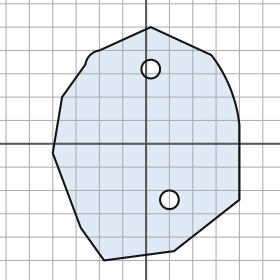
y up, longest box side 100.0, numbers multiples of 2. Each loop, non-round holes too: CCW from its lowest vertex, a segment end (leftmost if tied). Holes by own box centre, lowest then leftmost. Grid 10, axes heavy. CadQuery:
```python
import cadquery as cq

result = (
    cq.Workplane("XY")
    .moveTo(-18.0, -50.0)
    .lineTo(12.0, -46.0)
    .lineTo(40.0, -24.0)
    .lineTo(40.0, 8.0)
    .threePointArc((36.0, 24.0), (28.0, 38.0))
    .lineTo(2.0, 50.0)
    .lineTo(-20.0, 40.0)
    .threePointArc((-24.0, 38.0), (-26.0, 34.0))
    .lineTo(-36.0, 20.0)
    .lineTo(-40.0, -4.0)
    .lineTo(-28.0, -36.0)
    .close()
    .moveTo(10.0, -24.0)
    .circle(4.0)
    .moveTo(2.0, 32.0)
    .circle(4.0)
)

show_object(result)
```